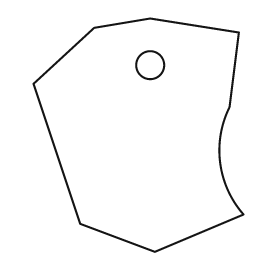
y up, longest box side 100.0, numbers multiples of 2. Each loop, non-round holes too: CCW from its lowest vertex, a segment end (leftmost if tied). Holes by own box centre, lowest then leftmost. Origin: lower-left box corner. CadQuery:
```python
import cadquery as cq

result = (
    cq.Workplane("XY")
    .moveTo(52.0, 0.0)
    .lineTo(90.0, 16.0)
    .threePointArc((80.0, 38.0), (84.0, 62.0))
    .lineTo(88.0, 94.0)
    .lineTo(50.0, 100.0)
    .lineTo(26.0, 96.0)
    .lineTo(0.0, 72.0)
    .lineTo(20.0, 12.0)
    .close()
    .moveTo(50.0, 80.0)
    .circle(6.0)
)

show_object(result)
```